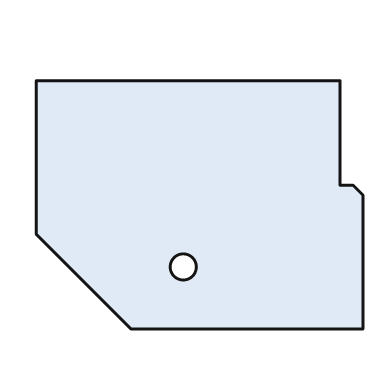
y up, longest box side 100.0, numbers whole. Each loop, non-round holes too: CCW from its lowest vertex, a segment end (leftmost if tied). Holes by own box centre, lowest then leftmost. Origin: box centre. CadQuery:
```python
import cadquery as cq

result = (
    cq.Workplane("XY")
    .moveTo(-21.0, -38.0)
    .lineTo(50.0, -38.0)
    .lineTo(50.0, 3.0)
    .lineTo(47.0, 6.0)
    .lineTo(43.0, 6.0)
    .lineTo(43.0, 38.0)
    .lineTo(-50.0, 38.0)
    .lineTo(-50.0, -9.0)
    .close()
    .moveTo(-5.0, -19.0)
    .circle(4.0)
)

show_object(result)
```